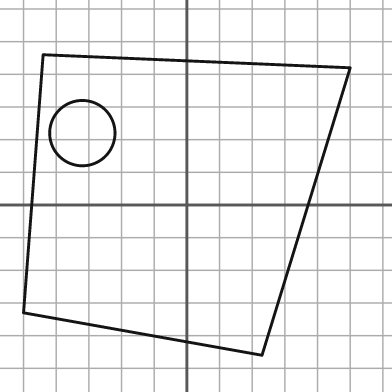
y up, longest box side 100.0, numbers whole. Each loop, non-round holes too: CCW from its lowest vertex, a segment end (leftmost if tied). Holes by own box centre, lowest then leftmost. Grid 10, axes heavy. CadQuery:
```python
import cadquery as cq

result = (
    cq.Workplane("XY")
    .moveTo(23.0, -46.0)
    .lineTo(50.0, 42.0)
    .lineTo(-44.0, 46.0)
    .lineTo(-50.0, -33.0)
    .close()
    .moveTo(-32.0, 22.0)
    .circle(10.0)
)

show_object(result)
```